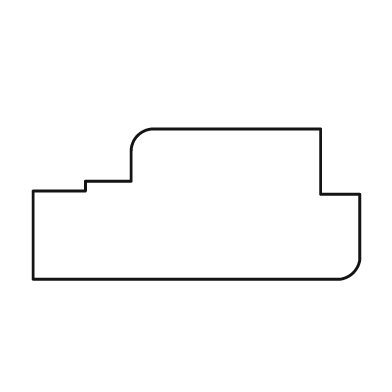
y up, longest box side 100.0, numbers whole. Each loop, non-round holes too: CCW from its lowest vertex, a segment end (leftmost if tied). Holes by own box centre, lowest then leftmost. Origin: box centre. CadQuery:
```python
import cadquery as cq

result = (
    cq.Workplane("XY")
    .moveTo(-50.0, -23.0)
    .lineTo(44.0, -23.0)
    .threePointArc((48.0, -21.0), (50.0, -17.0))
    .lineTo(50.0, 3.0)
    .lineTo(38.0, 3.0)
    .lineTo(38.0, 23.0)
    .lineTo(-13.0, 23.0)
    .threePointArc((-18.0, 21.0), (-20.0, 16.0))
    .lineTo(-20.0, 7.0)
    .lineTo(-34.0, 7.0)
    .lineTo(-34.0, 4.0)
    .lineTo(-50.0, 4.0)
    .close()
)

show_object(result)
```